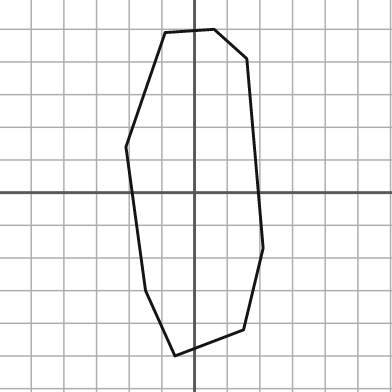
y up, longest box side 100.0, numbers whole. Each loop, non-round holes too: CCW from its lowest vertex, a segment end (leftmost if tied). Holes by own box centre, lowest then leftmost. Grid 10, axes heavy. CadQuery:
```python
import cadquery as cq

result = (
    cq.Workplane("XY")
    .moveTo(-6.0, -50.0)
    .lineTo(15.0, -42.0)
    .lineTo(21.0, -17.0)
    .lineTo(16.0, 41.0)
    .lineTo(6.0, 50.0)
    .lineTo(-9.0, 49.0)
    .lineTo(-21.0, 14.0)
    .lineTo(-15.0, -30.0)
    .close()
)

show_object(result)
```